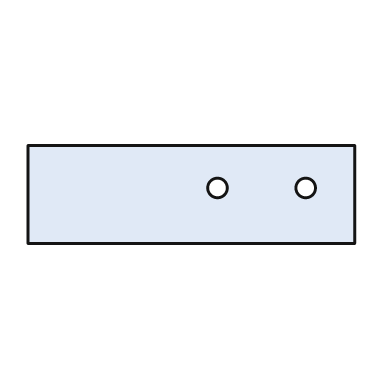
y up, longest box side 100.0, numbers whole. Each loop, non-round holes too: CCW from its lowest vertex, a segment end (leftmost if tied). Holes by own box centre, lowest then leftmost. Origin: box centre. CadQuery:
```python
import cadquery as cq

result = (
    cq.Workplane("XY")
    .moveTo(-50.0, -15.0)
    .lineTo(50.0, -15.0)
    .lineTo(50.0, 15.0)
    .lineTo(-50.0, 15.0)
    .close()
    .moveTo(8.0, 2.0)
    .circle(3.0)
    .moveTo(35.0, 2.0)
    .circle(3.0)
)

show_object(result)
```